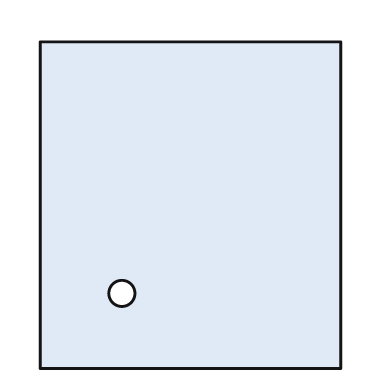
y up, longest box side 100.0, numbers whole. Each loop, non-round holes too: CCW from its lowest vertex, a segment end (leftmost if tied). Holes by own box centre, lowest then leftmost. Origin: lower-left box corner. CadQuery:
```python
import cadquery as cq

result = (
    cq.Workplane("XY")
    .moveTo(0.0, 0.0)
    .lineTo(92.0, 0.0)
    .lineTo(92.0, 100.0)
    .lineTo(0.0, 100.0)
    .close()
    .moveTo(25.0, 23.0)
    .circle(4.0)
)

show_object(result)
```